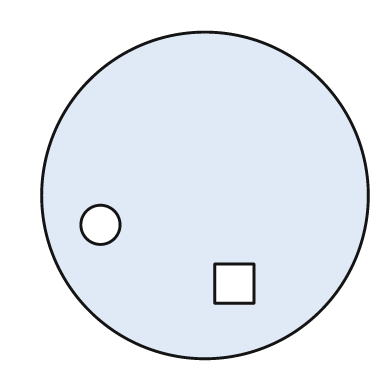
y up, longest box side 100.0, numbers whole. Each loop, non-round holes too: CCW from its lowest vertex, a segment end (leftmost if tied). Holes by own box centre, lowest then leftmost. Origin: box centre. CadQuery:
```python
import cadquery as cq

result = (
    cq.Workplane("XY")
    .moveTo(0.0, 0.0)
    .circle(50.0)
    .moveTo(3.0, -33.0)
    .lineTo(15.0, -33.0)
    .lineTo(15.0, -21.0)
    .lineTo(3.0, -21.0)
    .close()
    .moveTo(-32.0, -9.0)
    .circle(6.0)
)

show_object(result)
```